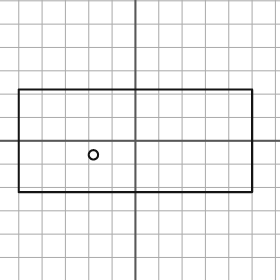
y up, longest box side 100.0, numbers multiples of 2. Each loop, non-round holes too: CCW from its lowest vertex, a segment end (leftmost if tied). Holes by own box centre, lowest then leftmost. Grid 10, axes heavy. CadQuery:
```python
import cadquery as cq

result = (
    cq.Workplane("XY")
    .moveTo(-50.0, -22.0)
    .lineTo(50.0, -22.0)
    .lineTo(50.0, 22.0)
    .lineTo(-50.0, 22.0)
    .close()
    .moveTo(-18.0, -6.0)
    .circle(2.0)
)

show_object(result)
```